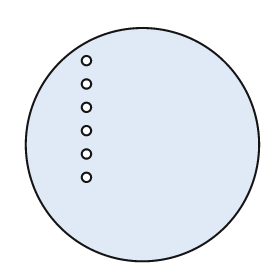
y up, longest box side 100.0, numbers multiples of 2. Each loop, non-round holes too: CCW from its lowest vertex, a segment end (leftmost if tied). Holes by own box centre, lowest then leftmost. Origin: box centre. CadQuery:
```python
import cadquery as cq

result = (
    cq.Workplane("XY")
    .moveTo(0.0, 0.0)
    .circle(50.0)
    .moveTo(-24.0, -14.0)
    .circle(2.0)
    .moveTo(-24.0, -4.0)
    .circle(2.0)
    .moveTo(-24.0, 6.0)
    .circle(2.0)
    .moveTo(-24.0, 16.0)
    .circle(2.0)
    .moveTo(-24.0, 26.0)
    .circle(2.0)
    .moveTo(-24.0, 36.0)
    .circle(2.0)
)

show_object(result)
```